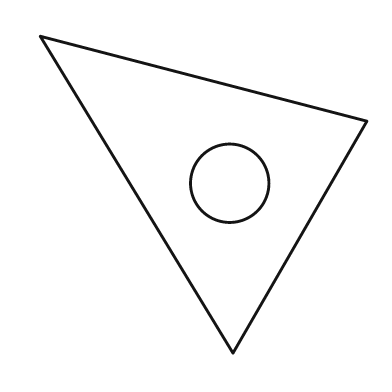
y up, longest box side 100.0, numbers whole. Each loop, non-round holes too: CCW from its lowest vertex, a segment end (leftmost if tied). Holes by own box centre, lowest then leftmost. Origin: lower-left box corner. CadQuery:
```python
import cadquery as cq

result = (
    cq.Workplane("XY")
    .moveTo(59.0, 0.0)
    .lineTo(100.0, 71.0)
    .lineTo(0.0, 97.0)
    .close()
    .moveTo(58.0, 52.0)
    .circle(12.0)
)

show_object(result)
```